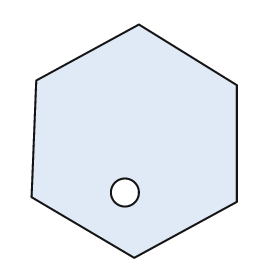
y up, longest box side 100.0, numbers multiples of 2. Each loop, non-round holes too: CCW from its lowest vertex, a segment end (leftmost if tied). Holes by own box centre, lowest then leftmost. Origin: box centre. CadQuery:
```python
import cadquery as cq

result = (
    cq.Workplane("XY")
    .moveTo(0.0, -50.0)
    .lineTo(44.0, -26.0)
    .lineTo(44.0, 24.0)
    .lineTo(2.0, 50.0)
    .lineTo(-42.0, 26.0)
    .lineTo(-44.0, -24.0)
    .close()
    .moveTo(-4.0, -22.0)
    .circle(6.0)
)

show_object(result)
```